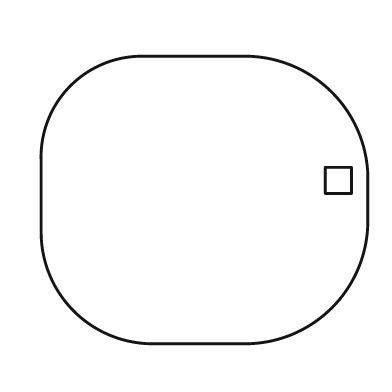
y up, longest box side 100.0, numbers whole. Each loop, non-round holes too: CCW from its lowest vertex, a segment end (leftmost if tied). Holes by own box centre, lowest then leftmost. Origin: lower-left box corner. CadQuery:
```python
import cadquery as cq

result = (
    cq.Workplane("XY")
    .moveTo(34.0, 0.0)
    .lineTo(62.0, 0.0)
    .threePointArc((89.0, 11.0), (100.0, 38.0))
    .lineTo(100.0, 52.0)
    .threePointArc((89.0, 77.0), (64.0, 88.0))
    .lineTo(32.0, 88.0)
    .threePointArc((9.0, 79.0), (0.0, 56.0))
    .lineTo(0.0, 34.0)
    .threePointArc((10.0, 10.0), (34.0, 0.0))
    .close()
    .moveTo(87.0, 46.0)
    .lineTo(95.0, 46.0)
    .lineTo(95.0, 54.0)
    .lineTo(87.0, 54.0)
    .close()
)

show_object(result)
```